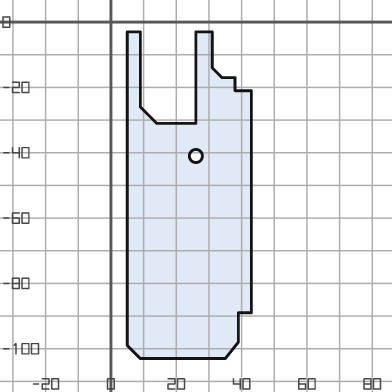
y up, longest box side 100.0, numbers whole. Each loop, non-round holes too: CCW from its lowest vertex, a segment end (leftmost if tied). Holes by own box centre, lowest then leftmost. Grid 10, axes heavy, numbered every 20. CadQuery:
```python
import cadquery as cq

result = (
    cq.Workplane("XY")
    .moveTo(9.0, -103.0)
    .lineTo(35.0, -103.0)
    .lineTo(39.0, -98.0)
    .lineTo(39.0, -89.0)
    .lineTo(43.0, -89.0)
    .lineTo(43.0, -21.0)
    .lineTo(38.0, -21.0)
    .lineTo(38.0, -17.0)
    .lineTo(34.0, -17.0)
    .lineTo(31.0, -14.0)
    .lineTo(31.0, -3.0)
    .lineTo(26.0, -3.0)
    .lineTo(26.0, -31.0)
    .lineTo(14.0, -31.0)
    .lineTo(9.0, -26.0)
    .lineTo(9.0, -3.0)
    .lineTo(5.0, -3.0)
    .lineTo(5.0, -99.0)
    .close()
    .moveTo(26.0, -41.0)
    .circle(2.0)
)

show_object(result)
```